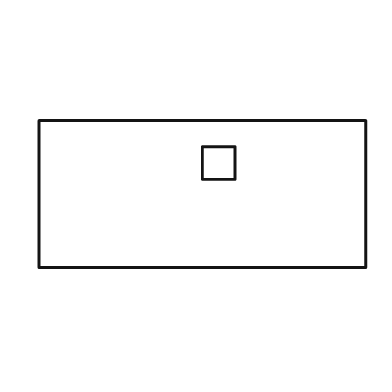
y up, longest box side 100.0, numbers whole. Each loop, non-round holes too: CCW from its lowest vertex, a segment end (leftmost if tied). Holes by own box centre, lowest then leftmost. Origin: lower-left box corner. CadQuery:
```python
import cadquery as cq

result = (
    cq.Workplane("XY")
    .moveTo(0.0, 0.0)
    .lineTo(100.0, 0.0)
    .lineTo(100.0, 45.0)
    .lineTo(0.0, 45.0)
    .close()
    .moveTo(50.0, 27.0)
    .lineTo(60.0, 27.0)
    .lineTo(60.0, 37.0)
    .lineTo(50.0, 37.0)
    .close()
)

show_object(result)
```